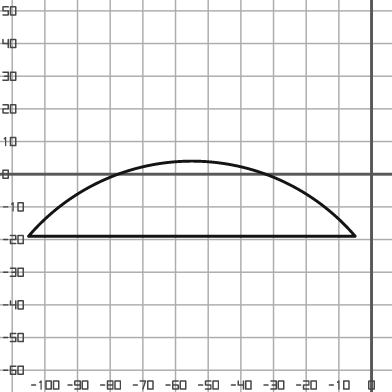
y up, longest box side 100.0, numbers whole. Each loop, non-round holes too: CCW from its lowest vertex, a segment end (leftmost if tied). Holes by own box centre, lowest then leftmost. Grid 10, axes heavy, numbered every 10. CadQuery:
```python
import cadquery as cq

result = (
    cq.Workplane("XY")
    .moveTo(-105.0, -19.0)
    .lineTo(-5.0, -19.0)
    .threePointArc((-55.0, 4.0), (-105.0, -19.0))
    .close()
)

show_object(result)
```